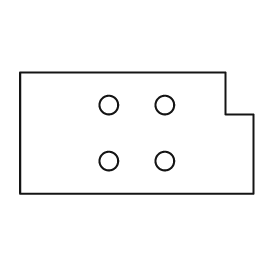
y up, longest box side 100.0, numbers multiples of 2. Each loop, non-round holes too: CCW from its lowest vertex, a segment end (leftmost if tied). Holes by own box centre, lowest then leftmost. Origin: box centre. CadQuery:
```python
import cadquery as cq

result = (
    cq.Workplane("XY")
    .moveTo(-50.0, -26.0)
    .lineTo(50.0, -26.0)
    .lineTo(50.0, 8.0)
    .lineTo(38.0, 8.0)
    .lineTo(38.0, 26.0)
    .lineTo(-50.0, 26.0)
    .close()
    .moveTo(-12.0, -12.0)
    .circle(4.0)
    .moveTo(12.0, -12.0)
    .circle(4.0)
    .moveTo(-12.0, 12.0)
    .circle(4.0)
    .moveTo(12.0, 12.0)
    .circle(4.0)
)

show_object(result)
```